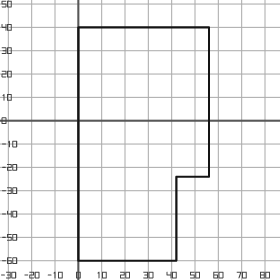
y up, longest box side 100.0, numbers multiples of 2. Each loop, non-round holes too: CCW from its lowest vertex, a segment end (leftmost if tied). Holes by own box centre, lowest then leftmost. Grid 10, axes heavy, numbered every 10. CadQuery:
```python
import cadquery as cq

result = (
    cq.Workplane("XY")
    .moveTo(0.0, -60.0)
    .lineTo(42.0, -60.0)
    .lineTo(42.0, -24.0)
    .lineTo(56.0, -24.0)
    .lineTo(56.0, 40.0)
    .lineTo(0.0, 40.0)
    .close()
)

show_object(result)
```